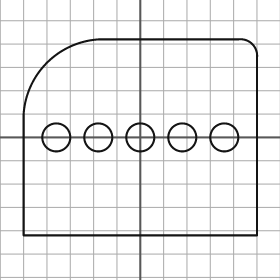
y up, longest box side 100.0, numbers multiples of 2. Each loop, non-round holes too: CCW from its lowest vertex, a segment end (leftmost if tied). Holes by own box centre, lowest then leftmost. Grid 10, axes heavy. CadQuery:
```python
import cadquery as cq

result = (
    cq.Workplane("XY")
    .moveTo(-50.0, -42.0)
    .lineTo(50.0, -42.0)
    .lineTo(50.0, 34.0)
    .threePointArc((48.0, 40.0), (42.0, 42.0))
    .lineTo(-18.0, 42.0)
    .threePointArc((-40.0, 32.0), (-50.0, 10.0))
    .close()
    .moveTo(-36.0, 0.0)
    .circle(6.0)
    .moveTo(-18.0, 0.0)
    .circle(6.0)
    .moveTo(0.0, 0.0)
    .circle(6.0)
    .moveTo(18.0, 0.0)
    .circle(6.0)
    .moveTo(36.0, 0.0)
    .circle(6.0)
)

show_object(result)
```